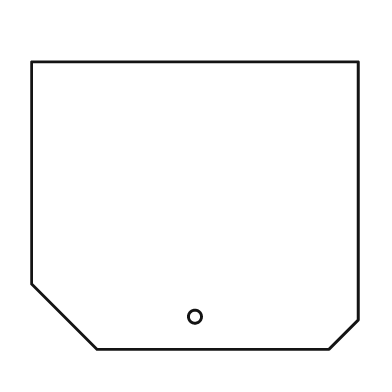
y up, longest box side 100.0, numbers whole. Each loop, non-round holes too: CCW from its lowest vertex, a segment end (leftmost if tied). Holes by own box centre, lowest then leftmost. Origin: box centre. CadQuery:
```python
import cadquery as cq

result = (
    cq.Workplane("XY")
    .moveTo(-30.0, -44.0)
    .lineTo(41.0, -44.0)
    .lineTo(50.0, -35.0)
    .lineTo(50.0, 44.0)
    .lineTo(-50.0, 44.0)
    .lineTo(-50.0, -24.0)
    .close()
    .moveTo(0.0, -34.0)
    .circle(2.0)
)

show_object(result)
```